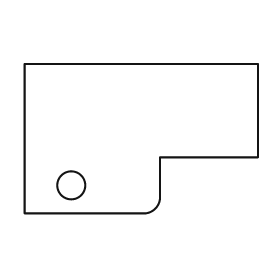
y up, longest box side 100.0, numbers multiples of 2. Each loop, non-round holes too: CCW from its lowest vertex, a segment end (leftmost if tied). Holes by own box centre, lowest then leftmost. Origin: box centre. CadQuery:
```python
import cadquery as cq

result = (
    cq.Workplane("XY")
    .moveTo(-50.0, -32.0)
    .lineTo(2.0, -32.0)
    .threePointArc((6.0, -30.0), (8.0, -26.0))
    .lineTo(8.0, -8.0)
    .lineTo(50.0, -8.0)
    .lineTo(50.0, 32.0)
    .lineTo(-50.0, 32.0)
    .close()
    .moveTo(-30.0, -20.0)
    .circle(6.0)
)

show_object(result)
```